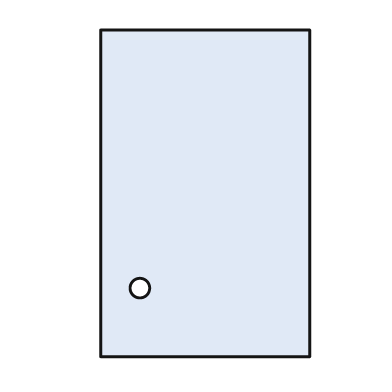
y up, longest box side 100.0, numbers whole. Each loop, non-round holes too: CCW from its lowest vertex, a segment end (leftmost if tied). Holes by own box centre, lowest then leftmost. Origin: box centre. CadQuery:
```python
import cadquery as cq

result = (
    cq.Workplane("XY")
    .moveTo(-32.0, -50.0)
    .lineTo(32.0, -50.0)
    .lineTo(32.0, 50.0)
    .lineTo(-32.0, 50.0)
    .close()
    .moveTo(-20.0, -29.0)
    .circle(3.0)
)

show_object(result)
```